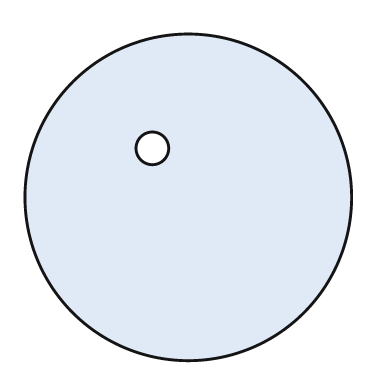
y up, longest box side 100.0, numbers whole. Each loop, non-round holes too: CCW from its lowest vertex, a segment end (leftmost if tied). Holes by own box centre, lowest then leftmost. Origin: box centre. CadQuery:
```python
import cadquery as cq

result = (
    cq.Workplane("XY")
    .moveTo(0.0, 0.0)
    .circle(50.0)
    .moveTo(-11.0, 15.0)
    .circle(5.0)
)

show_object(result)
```